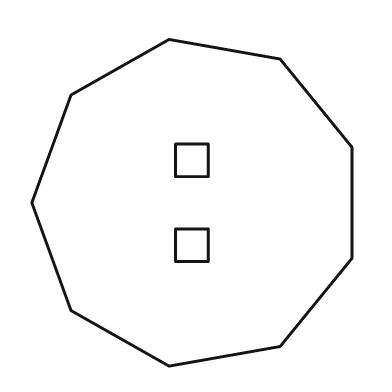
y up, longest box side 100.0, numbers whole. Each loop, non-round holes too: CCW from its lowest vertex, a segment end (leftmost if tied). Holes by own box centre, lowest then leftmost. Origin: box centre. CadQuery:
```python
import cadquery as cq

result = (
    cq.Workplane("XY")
    .moveTo(-7.0, -50.0)
    .lineTo(27.0, -44.0)
    .lineTo(49.0, -17.0)
    .lineTo(49.0, 17.0)
    .lineTo(27.0, 44.0)
    .lineTo(-7.0, 50.0)
    .lineTo(-37.0, 33.0)
    .lineTo(-49.0, 0.0)
    .lineTo(-37.0, -33.0)
    .close()
    .moveTo(-5.0, -18.0)
    .lineTo(5.0, -18.0)
    .lineTo(5.0, -8.0)
    .lineTo(-5.0, -8.0)
    .close()
    .moveTo(-5.0, 8.0)
    .lineTo(5.0, 8.0)
    .lineTo(5.0, 18.0)
    .lineTo(-5.0, 18.0)
    .close()
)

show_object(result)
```